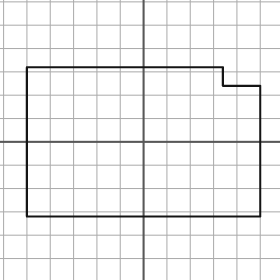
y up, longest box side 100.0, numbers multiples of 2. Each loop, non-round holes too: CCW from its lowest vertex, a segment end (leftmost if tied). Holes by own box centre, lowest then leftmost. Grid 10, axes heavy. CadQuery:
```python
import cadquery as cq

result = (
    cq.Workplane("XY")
    .moveTo(-50.0, -32.0)
    .lineTo(50.0, -32.0)
    .lineTo(50.0, 24.0)
    .lineTo(34.0, 24.0)
    .lineTo(34.0, 32.0)
    .lineTo(-50.0, 32.0)
    .close()
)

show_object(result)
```